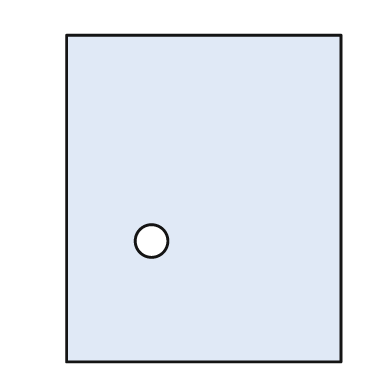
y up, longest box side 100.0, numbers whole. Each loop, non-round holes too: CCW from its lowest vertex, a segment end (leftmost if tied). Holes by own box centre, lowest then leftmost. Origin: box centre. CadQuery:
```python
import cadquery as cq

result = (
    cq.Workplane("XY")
    .moveTo(-42.0, -50.0)
    .lineTo(42.0, -50.0)
    .lineTo(42.0, 50.0)
    .lineTo(-42.0, 50.0)
    .close()
    .moveTo(-16.0, -13.0)
    .circle(5.0)
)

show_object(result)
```